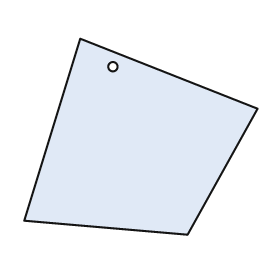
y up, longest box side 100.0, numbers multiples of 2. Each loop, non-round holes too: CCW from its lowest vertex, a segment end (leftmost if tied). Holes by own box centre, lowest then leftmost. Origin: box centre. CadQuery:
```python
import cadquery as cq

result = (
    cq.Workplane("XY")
    .moveTo(20.0, -42.0)
    .lineTo(50.0, 12.0)
    .lineTo(-26.0, 42.0)
    .lineTo(-50.0, -36.0)
    .close()
    .moveTo(-12.0, 30.0)
    .circle(2.0)
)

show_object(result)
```